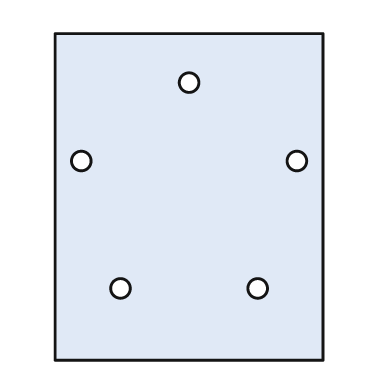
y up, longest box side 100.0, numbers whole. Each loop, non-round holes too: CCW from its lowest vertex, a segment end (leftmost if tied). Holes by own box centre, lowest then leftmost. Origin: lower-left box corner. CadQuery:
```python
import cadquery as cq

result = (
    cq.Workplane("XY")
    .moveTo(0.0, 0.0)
    .lineTo(82.0, 0.0)
    .lineTo(82.0, 100.0)
    .lineTo(0.0, 100.0)
    .close()
    .moveTo(20.0, 22.0)
    .circle(3.0)
    .moveTo(62.0, 22.0)
    .circle(3.0)
    .moveTo(8.0, 61.0)
    .circle(3.0)
    .moveTo(74.0, 61.0)
    .circle(3.0)
    .moveTo(41.0, 85.0)
    .circle(3.0)
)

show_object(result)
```